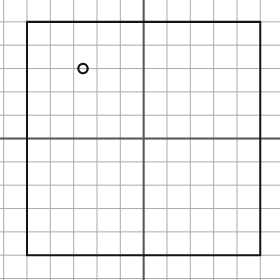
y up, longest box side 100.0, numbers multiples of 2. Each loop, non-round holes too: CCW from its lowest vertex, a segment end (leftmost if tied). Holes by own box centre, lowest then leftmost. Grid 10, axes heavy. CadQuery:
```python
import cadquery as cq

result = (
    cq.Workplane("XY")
    .moveTo(-50.0, -50.0)
    .lineTo(50.0, -50.0)
    .lineTo(50.0, 50.0)
    .lineTo(-50.0, 50.0)
    .close()
    .moveTo(-26.0, 30.0)
    .circle(2.0)
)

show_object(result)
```